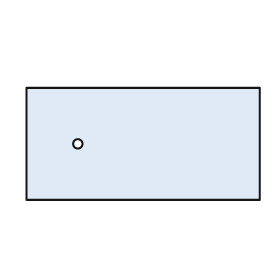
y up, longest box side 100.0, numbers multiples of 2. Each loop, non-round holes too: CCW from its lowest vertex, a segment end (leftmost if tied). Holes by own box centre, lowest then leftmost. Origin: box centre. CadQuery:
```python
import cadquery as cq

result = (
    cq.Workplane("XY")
    .moveTo(-50.0, -24.0)
    .lineTo(50.0, -24.0)
    .lineTo(50.0, 24.0)
    .lineTo(-50.0, 24.0)
    .close()
    .moveTo(-28.0, 0.0)
    .circle(2.0)
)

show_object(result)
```